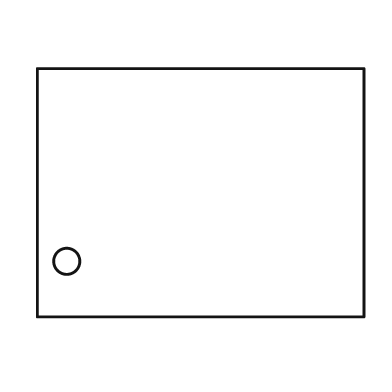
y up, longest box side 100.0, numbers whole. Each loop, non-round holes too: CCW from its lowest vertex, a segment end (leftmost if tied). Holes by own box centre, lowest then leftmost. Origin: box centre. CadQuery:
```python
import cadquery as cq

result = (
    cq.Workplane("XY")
    .moveTo(-50.0, -38.0)
    .lineTo(50.0, -38.0)
    .lineTo(50.0, 38.0)
    .lineTo(-50.0, 38.0)
    .close()
    .moveTo(-41.0, -21.0)
    .circle(4.0)
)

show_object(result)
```